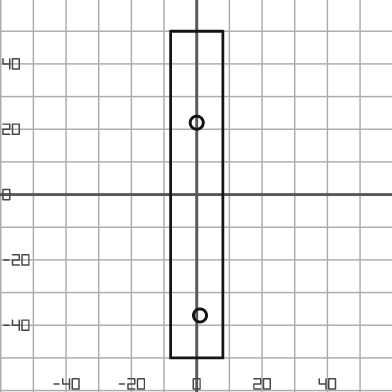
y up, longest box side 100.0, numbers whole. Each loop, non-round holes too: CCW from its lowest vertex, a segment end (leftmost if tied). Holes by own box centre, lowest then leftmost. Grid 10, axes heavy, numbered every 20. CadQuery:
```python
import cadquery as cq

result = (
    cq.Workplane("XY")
    .moveTo(-8.0, -50.0)
    .lineTo(8.0, -50.0)
    .lineTo(8.0, 50.0)
    .lineTo(-8.0, 50.0)
    .close()
    .moveTo(1.0, -37.0)
    .circle(2.0)
    .moveTo(0.0, 22.0)
    .circle(2.0)
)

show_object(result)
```